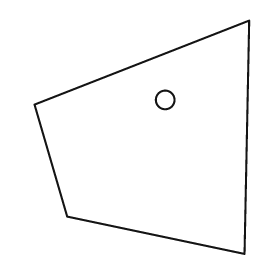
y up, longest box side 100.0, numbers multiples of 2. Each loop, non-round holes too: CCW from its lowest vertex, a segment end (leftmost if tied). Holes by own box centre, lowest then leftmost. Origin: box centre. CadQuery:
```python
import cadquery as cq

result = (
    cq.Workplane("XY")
    .moveTo(44.0, -50.0)
    .lineTo(46.0, 50.0)
    .lineTo(-46.0, 14.0)
    .lineTo(-32.0, -34.0)
    .close()
    .moveTo(10.0, 16.0)
    .circle(4.0)
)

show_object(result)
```